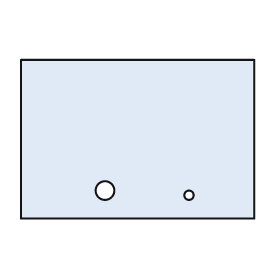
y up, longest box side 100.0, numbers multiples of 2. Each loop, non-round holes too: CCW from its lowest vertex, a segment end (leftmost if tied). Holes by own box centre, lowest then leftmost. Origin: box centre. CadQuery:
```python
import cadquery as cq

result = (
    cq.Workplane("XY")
    .moveTo(-50.0, -34.0)
    .lineTo(50.0, -34.0)
    .lineTo(50.0, 34.0)
    .lineTo(-50.0, 34.0)
    .close()
    .moveTo(22.0, -24.0)
    .circle(2.0)
    .moveTo(-14.0, -22.0)
    .circle(4.0)
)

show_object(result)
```